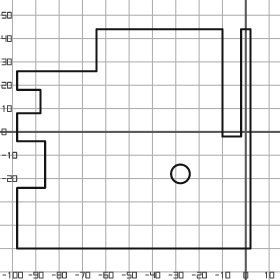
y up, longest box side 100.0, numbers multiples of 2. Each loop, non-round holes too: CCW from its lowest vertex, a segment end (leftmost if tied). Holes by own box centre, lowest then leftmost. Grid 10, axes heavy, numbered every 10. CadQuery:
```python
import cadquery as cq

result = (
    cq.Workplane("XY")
    .moveTo(-98.0, -50.0)
    .lineTo(2.0, -50.0)
    .lineTo(2.0, 44.0)
    .lineTo(-2.0, 44.0)
    .lineTo(-2.0, -2.0)
    .lineTo(-10.0, -2.0)
    .lineTo(-10.0, 44.0)
    .lineTo(-64.0, 44.0)
    .lineTo(-64.0, 26.0)
    .lineTo(-98.0, 26.0)
    .lineTo(-98.0, 18.0)
    .lineTo(-88.0, 18.0)
    .lineTo(-88.0, 8.0)
    .lineTo(-98.0, 8.0)
    .lineTo(-98.0, -4.0)
    .lineTo(-86.0, -4.0)
    .lineTo(-86.0, -24.0)
    .lineTo(-98.0, -24.0)
    .close()
    .moveTo(-28.0, -18.0)
    .circle(4.0)
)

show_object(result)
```